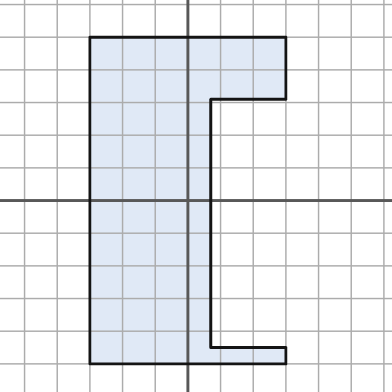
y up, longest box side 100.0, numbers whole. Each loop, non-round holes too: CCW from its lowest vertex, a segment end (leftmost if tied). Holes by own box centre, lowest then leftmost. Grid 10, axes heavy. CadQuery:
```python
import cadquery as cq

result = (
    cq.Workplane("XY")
    .moveTo(-30.0, -50.0)
    .lineTo(30.0, -50.0)
    .lineTo(30.0, -45.0)
    .lineTo(7.0, -45.0)
    .lineTo(7.0, 31.0)
    .lineTo(30.0, 31.0)
    .lineTo(30.0, 50.0)
    .lineTo(-30.0, 50.0)
    .close()
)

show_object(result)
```